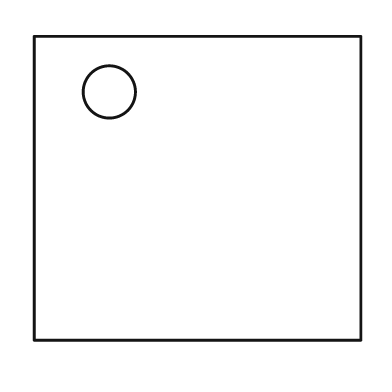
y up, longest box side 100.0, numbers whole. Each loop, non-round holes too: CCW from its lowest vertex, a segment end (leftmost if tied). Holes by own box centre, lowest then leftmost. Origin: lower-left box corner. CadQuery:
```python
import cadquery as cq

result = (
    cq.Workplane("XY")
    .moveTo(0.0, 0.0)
    .lineTo(100.0, 0.0)
    .lineTo(100.0, 93.0)
    .lineTo(0.0, 93.0)
    .close()
    .moveTo(23.0, 76.0)
    .circle(8.0)
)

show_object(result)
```